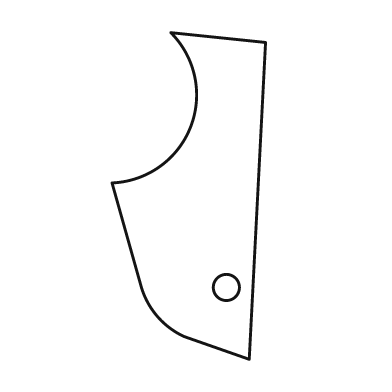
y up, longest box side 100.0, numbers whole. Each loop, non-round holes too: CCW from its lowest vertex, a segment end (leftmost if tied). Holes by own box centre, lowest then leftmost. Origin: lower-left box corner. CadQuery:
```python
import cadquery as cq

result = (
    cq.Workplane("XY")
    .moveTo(42.0, 0.0)
    .lineTo(47.0, 97.0)
    .lineTo(18.0, 100.0)
    .threePointArc((24.0, 71.0), (0.0, 54.0))
    .lineTo(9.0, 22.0)
    .threePointArc((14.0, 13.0), (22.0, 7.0))
    .close()
    .moveTo(35.0, 22.0)
    .circle(4.0)
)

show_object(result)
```